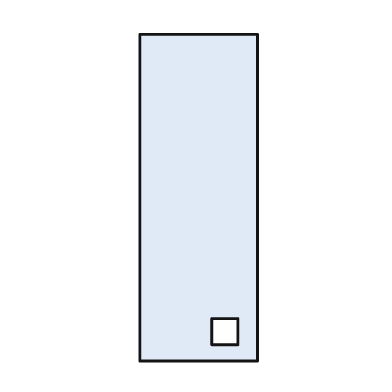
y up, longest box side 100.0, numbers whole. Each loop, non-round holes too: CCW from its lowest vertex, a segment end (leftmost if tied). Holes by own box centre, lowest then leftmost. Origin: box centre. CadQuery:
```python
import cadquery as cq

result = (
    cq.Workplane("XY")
    .moveTo(-18.0, -50.0)
    .lineTo(18.0, -50.0)
    .lineTo(18.0, 50.0)
    .lineTo(-18.0, 50.0)
    .close()
    .moveTo(4.0, -45.0)
    .lineTo(12.0, -45.0)
    .lineTo(12.0, -37.0)
    .lineTo(4.0, -37.0)
    .close()
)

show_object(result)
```